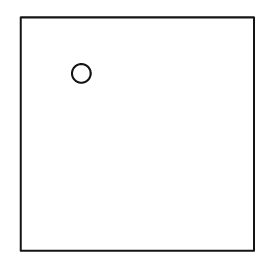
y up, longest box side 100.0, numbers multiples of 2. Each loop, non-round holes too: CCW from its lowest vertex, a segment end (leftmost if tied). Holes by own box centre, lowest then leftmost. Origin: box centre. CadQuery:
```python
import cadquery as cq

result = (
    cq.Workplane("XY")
    .moveTo(-50.0, -50.0)
    .lineTo(50.0, -50.0)
    .lineTo(50.0, 50.0)
    .lineTo(-50.0, 50.0)
    .close()
    .moveTo(-24.0, 26.0)
    .circle(4.0)
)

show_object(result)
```